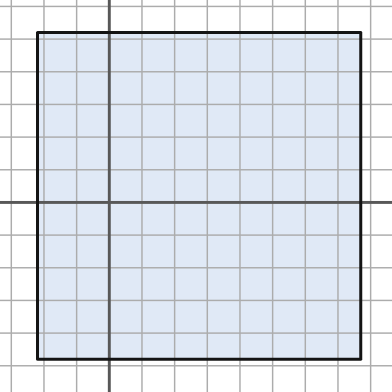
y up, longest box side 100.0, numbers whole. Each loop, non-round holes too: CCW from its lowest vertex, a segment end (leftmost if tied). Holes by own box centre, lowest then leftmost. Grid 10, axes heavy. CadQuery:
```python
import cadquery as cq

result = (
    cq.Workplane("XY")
    .moveTo(-22.0, -48.0)
    .lineTo(77.0, -48.0)
    .lineTo(77.0, 52.0)
    .lineTo(-22.0, 52.0)
    .close()
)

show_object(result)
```